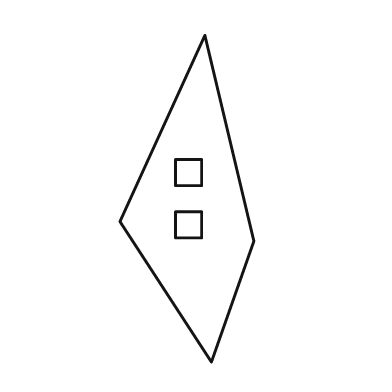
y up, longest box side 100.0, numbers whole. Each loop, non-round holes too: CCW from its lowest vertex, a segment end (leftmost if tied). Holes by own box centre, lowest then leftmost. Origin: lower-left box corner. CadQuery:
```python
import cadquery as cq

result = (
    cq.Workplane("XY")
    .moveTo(28.0, 0.0)
    .lineTo(41.0, 37.0)
    .lineTo(26.0, 100.0)
    .lineTo(0.0, 43.0)
    .close()
    .moveTo(17.0, 38.0)
    .lineTo(25.0, 38.0)
    .lineTo(25.0, 46.0)
    .lineTo(17.0, 46.0)
    .close()
    .moveTo(17.0, 54.0)
    .lineTo(25.0, 54.0)
    .lineTo(25.0, 62.0)
    .lineTo(17.0, 62.0)
    .close()
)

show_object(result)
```